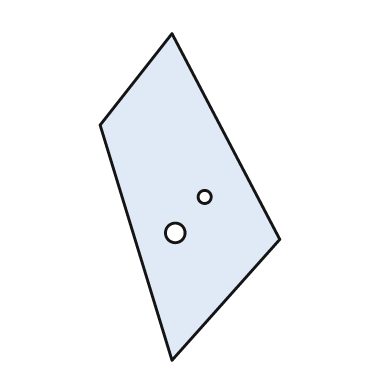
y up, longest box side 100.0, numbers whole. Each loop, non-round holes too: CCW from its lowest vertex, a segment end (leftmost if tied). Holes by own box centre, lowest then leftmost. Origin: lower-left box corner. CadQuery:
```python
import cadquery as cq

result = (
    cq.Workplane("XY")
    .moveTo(22.0, 0.0)
    .lineTo(55.0, 37.0)
    .lineTo(22.0, 100.0)
    .lineTo(0.0, 72.0)
    .close()
    .moveTo(23.0, 39.0)
    .circle(3.0)
    .moveTo(32.0, 50.0)
    .circle(2.0)
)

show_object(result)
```